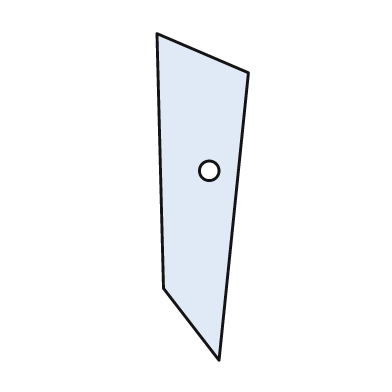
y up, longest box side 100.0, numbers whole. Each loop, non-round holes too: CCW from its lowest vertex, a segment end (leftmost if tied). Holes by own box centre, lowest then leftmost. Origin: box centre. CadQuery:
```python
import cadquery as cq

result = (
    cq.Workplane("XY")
    .moveTo(5.0, -50.0)
    .lineTo(14.0, 38.0)
    .lineTo(-14.0, 50.0)
    .lineTo(-12.0, -28.0)
    .close()
    .moveTo(2.0, 8.0)
    .circle(3.0)
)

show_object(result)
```